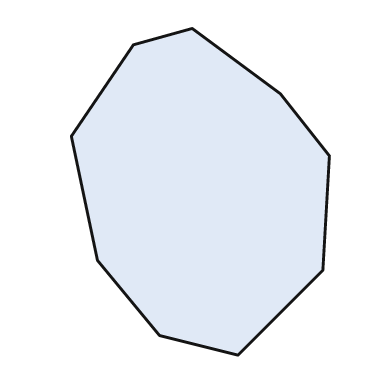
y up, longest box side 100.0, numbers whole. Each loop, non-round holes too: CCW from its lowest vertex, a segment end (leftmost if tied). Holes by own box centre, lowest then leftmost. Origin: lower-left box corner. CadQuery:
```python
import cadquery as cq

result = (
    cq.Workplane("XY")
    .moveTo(51.0, 0.0)
    .lineTo(77.0, 26.0)
    .lineTo(79.0, 61.0)
    .lineTo(64.0, 80.0)
    .lineTo(37.0, 100.0)
    .lineTo(19.0, 95.0)
    .lineTo(0.0, 67.0)
    .lineTo(8.0, 29.0)
    .lineTo(27.0, 6.0)
    .close()
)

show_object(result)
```